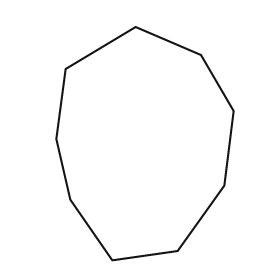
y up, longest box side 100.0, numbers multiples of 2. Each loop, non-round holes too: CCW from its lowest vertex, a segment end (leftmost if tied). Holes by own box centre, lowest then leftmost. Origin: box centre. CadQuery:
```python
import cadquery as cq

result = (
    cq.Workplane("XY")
    .moveTo(-14.0, -50.0)
    .lineTo(14.0, -46.0)
    .lineTo(34.0, -18.0)
    .lineTo(38.0, 14.0)
    .lineTo(24.0, 38.0)
    .lineTo(-4.0, 50.0)
    .lineTo(-34.0, 32.0)
    .lineTo(-38.0, 2.0)
    .lineTo(-32.0, -24.0)
    .close()
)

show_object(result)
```